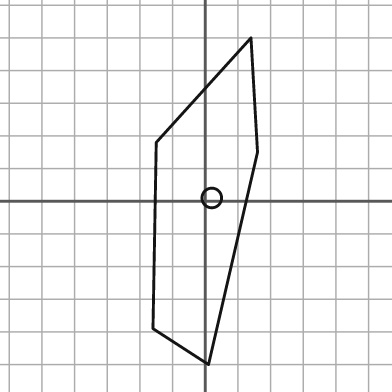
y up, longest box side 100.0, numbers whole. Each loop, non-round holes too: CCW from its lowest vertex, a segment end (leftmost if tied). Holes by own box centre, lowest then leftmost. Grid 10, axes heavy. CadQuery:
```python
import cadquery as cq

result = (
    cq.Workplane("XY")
    .moveTo(1.0, -50.0)
    .lineTo(16.0, 15.0)
    .lineTo(14.0, 50.0)
    .lineTo(-15.0, 18.0)
    .lineTo(-16.0, -39.0)
    .close()
    .moveTo(2.0, 1.0)
    .circle(3.0)
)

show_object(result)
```